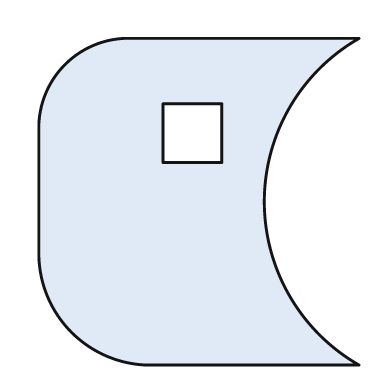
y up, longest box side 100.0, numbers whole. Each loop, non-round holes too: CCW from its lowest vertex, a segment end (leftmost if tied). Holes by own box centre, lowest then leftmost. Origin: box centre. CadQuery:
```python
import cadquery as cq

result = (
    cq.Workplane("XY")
    .moveTo(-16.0, -50.0)
    .lineTo(49.0, -50.0)
    .threePointArc((20.0, 0.0), (49.0, 50.0))
    .lineTo(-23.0, 50.0)
    .threePointArc((-41.0, 42.0), (-49.0, 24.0))
    .lineTo(-49.0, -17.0)
    .threePointArc((-39.0, -40.0), (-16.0, -50.0))
    .close()
    .moveTo(-11.0, 12.0)
    .lineTo(7.0, 12.0)
    .lineTo(7.0, 30.0)
    .lineTo(-11.0, 30.0)
    .close()
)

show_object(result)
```